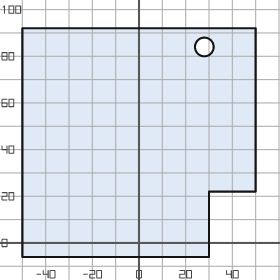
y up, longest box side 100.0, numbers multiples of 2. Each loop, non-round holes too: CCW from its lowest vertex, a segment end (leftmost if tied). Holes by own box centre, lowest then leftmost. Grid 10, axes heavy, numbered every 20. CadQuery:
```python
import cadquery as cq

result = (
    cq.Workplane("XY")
    .moveTo(-50.0, -6.0)
    .lineTo(30.0, -6.0)
    .lineTo(30.0, 22.0)
    .lineTo(50.0, 22.0)
    .lineTo(50.0, 92.0)
    .lineTo(-50.0, 92.0)
    .close()
    .moveTo(28.0, 84.0)
    .circle(4.0)
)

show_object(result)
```